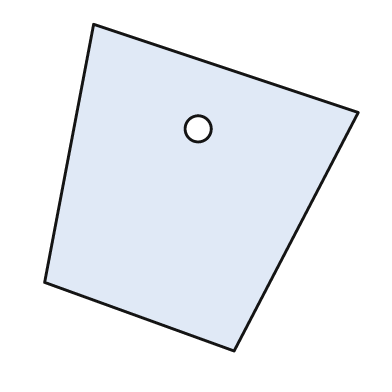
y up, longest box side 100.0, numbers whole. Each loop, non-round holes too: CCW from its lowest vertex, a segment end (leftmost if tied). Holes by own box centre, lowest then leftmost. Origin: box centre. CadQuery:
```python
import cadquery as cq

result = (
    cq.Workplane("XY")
    .moveTo(10.0, -50.0)
    .lineTo(48.0, 23.0)
    .lineTo(-33.0, 50.0)
    .lineTo(-48.0, -29.0)
    .close()
    .moveTo(-1.0, 18.0)
    .circle(4.0)
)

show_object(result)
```